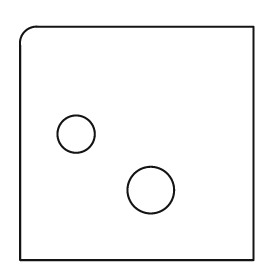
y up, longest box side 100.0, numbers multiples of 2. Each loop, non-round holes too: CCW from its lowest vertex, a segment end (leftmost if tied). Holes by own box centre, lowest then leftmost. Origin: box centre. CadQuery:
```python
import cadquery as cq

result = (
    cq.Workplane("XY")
    .moveTo(-50.0, -50.0)
    .lineTo(50.0, -50.0)
    .lineTo(50.0, 50.0)
    .lineTo(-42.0, 50.0)
    .threePointArc((-48.0, 48.0), (-50.0, 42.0))
    .close()
    .moveTo(6.0, -20.0)
    .circle(10.0)
    .moveTo(-26.0, 4.0)
    .circle(8.0)
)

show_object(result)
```